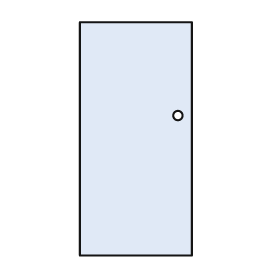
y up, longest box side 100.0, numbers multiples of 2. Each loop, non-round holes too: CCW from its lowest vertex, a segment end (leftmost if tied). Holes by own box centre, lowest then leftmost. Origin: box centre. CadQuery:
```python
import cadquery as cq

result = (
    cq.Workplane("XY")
    .moveTo(-24.0, -50.0)
    .lineTo(24.0, -50.0)
    .lineTo(24.0, 50.0)
    .lineTo(-24.0, 50.0)
    .close()
    .moveTo(18.0, 10.0)
    .circle(2.0)
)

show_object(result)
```